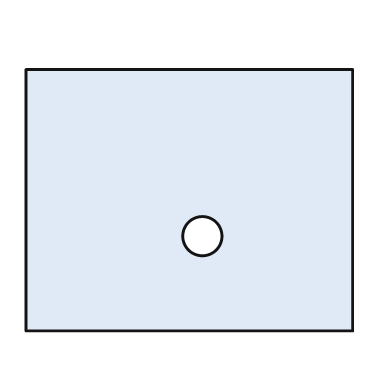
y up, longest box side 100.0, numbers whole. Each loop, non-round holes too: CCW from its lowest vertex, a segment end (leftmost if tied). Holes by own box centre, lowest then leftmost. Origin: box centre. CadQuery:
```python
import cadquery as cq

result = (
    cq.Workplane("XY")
    .moveTo(-50.0, -40.0)
    .lineTo(50.0, -40.0)
    .lineTo(50.0, 40.0)
    .lineTo(-50.0, 40.0)
    .close()
    .moveTo(4.0, -11.0)
    .circle(6.0)
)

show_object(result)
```